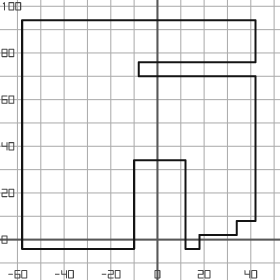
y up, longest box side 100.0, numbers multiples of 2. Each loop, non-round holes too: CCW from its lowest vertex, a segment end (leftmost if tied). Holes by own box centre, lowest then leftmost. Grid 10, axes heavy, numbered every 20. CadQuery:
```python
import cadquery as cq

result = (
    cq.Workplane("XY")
    .moveTo(-58.0, -4.0)
    .lineTo(-10.0, -4.0)
    .lineTo(-10.0, 34.0)
    .lineTo(12.0, 34.0)
    .lineTo(12.0, -4.0)
    .lineTo(18.0, -4.0)
    .lineTo(18.0, 2.0)
    .lineTo(34.0, 2.0)
    .lineTo(34.0, 8.0)
    .lineTo(42.0, 8.0)
    .lineTo(42.0, 70.0)
    .lineTo(-8.0, 70.0)
    .lineTo(-8.0, 76.0)
    .lineTo(42.0, 76.0)
    .lineTo(42.0, 94.0)
    .lineTo(-58.0, 94.0)
    .close()
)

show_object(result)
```